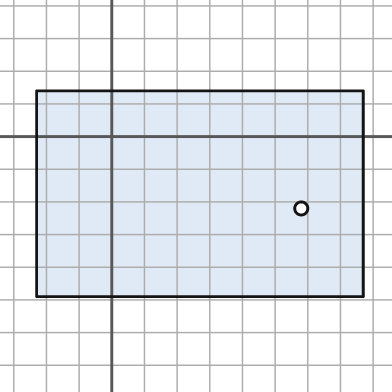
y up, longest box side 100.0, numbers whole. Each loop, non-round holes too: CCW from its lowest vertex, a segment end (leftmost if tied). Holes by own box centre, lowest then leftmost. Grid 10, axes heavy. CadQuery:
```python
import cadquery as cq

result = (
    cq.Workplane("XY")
    .moveTo(-23.0, -49.0)
    .lineTo(77.0, -49.0)
    .lineTo(77.0, 14.0)
    .lineTo(-23.0, 14.0)
    .close()
    .moveTo(58.0, -22.0)
    .circle(2.0)
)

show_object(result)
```